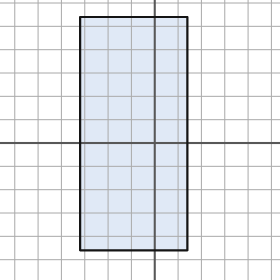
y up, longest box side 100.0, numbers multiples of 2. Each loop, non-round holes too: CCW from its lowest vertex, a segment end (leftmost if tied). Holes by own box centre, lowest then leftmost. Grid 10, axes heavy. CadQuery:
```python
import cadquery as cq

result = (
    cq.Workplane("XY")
    .moveTo(-32.0, -46.0)
    .lineTo(14.0, -46.0)
    .lineTo(14.0, 54.0)
    .lineTo(-32.0, 54.0)
    .close()
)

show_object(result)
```